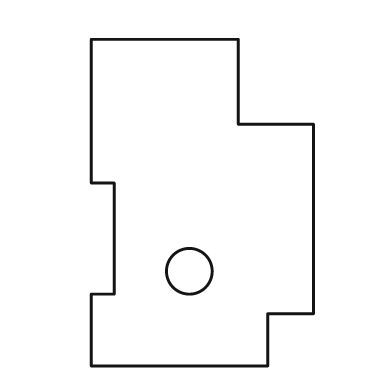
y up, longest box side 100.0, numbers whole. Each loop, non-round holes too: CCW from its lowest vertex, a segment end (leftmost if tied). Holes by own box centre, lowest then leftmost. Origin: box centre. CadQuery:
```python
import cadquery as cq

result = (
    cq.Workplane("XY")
    .moveTo(-34.0, -50.0)
    .lineTo(20.0, -50.0)
    .lineTo(20.0, -34.0)
    .lineTo(34.0, -34.0)
    .lineTo(34.0, 24.0)
    .lineTo(11.0, 24.0)
    .lineTo(11.0, 50.0)
    .lineTo(-34.0, 50.0)
    .lineTo(-34.0, 6.0)
    .lineTo(-27.0, 6.0)
    .lineTo(-27.0, -28.0)
    .lineTo(-34.0, -28.0)
    .close()
    .moveTo(-4.0, -21.0)
    .circle(7.0)
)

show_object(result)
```